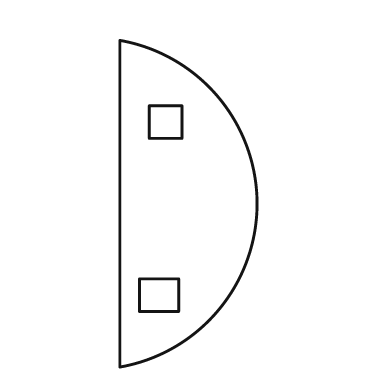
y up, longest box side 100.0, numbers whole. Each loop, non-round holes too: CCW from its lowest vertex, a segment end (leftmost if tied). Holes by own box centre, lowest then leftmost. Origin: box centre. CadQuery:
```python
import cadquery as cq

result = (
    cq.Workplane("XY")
    .moveTo(-21.0, -50.0)
    .threePointArc((21.0, 0.0), (-21.0, 50.0))
    .close()
    .moveTo(-15.0, -33.0)
    .lineTo(-3.0, -33.0)
    .lineTo(-3.0, -23.0)
    .lineTo(-15.0, -23.0)
    .close()
    .moveTo(-12.0, 20.0)
    .lineTo(-2.0, 20.0)
    .lineTo(-2.0, 30.0)
    .lineTo(-12.0, 30.0)
    .close()
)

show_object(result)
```